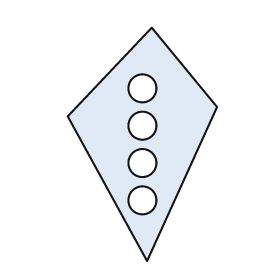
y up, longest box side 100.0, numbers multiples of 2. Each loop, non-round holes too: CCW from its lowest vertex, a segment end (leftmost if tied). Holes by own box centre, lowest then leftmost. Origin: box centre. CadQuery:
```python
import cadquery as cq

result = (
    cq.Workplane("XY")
    .moveTo(2.0, -50.0)
    .lineTo(32.0, 16.0)
    .lineTo(4.0, 50.0)
    .lineTo(-32.0, 12.0)
    .close()
    .moveTo(0.0, -24.0)
    .circle(6.0)
    .moveTo(0.0, -8.0)
    .circle(6.0)
    .moveTo(0.0, 8.0)
    .circle(6.0)
    .moveTo(0.0, 24.0)
    .circle(6.0)
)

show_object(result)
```